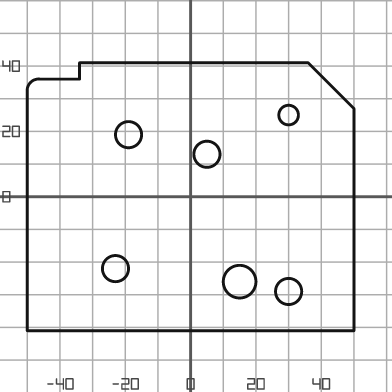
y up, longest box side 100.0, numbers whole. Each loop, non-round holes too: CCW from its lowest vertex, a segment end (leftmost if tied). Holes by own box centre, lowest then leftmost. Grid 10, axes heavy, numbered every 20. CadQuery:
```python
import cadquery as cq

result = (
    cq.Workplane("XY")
    .moveTo(-50.0, -41.0)
    .lineTo(50.0, -41.0)
    .lineTo(50.0, 27.0)
    .lineTo(36.0, 41.0)
    .lineTo(-34.0, 41.0)
    .lineTo(-34.0, 36.0)
    .lineTo(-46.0, 36.0)
    .threePointArc((-49.0, 35.0), (-50.0, 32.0))
    .close()
    .moveTo(30.0, -29.0)
    .circle(4.0)
    .moveTo(15.0, -26.0)
    .circle(5.0)
    .moveTo(-23.0, -22.0)
    .circle(4.0)
    .moveTo(5.0, 13.0)
    .circle(4.0)
    .moveTo(-19.0, 19.0)
    .circle(4.0)
    .moveTo(30.0, 25.0)
    .circle(3.0)
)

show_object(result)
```